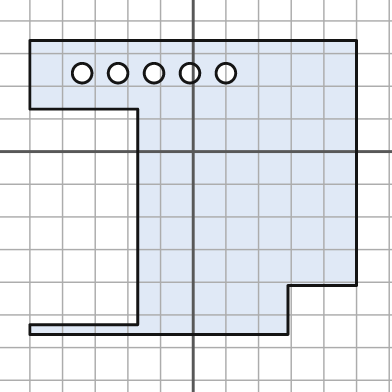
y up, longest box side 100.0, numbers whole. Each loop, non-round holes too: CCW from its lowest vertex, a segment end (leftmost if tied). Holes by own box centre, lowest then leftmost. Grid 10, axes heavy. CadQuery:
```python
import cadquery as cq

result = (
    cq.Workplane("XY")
    .moveTo(-50.0, -56.0)
    .lineTo(29.0, -56.0)
    .lineTo(29.0, -41.0)
    .lineTo(50.0, -41.0)
    .lineTo(50.0, 34.0)
    .lineTo(-50.0, 34.0)
    .lineTo(-50.0, 13.0)
    .lineTo(-17.0, 13.0)
    .lineTo(-17.0, -53.0)
    .lineTo(-50.0, -53.0)
    .close()
    .moveTo(-34.0, 24.0)
    .circle(3.0)
    .moveTo(-23.0, 24.0)
    .circle(3.0)
    .moveTo(-12.0, 24.0)
    .circle(3.0)
    .moveTo(-1.0, 24.0)
    .circle(3.0)
    .moveTo(10.0, 24.0)
    .circle(3.0)
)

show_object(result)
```